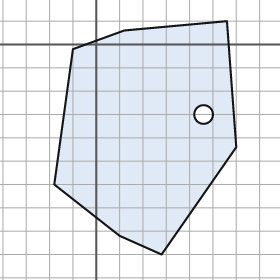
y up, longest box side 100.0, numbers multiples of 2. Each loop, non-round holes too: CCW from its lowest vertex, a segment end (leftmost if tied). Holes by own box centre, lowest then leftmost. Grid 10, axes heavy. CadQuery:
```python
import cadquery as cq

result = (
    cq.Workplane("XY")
    .moveTo(28.0, -90.0)
    .lineTo(60.0, -44.0)
    .lineTo(56.0, 10.0)
    .lineTo(12.0, 6.0)
    .lineTo(-10.0, -2.0)
    .lineTo(-18.0, -60.0)
    .lineTo(10.0, -82.0)
    .close()
    .moveTo(46.0, -30.0)
    .circle(4.0)
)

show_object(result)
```